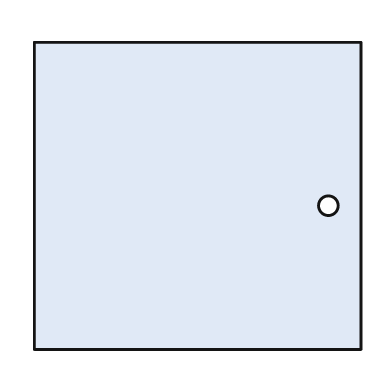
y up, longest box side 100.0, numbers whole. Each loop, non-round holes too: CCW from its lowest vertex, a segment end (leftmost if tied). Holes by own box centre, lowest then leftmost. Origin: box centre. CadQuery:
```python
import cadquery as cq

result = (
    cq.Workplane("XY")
    .moveTo(-50.0, -47.0)
    .lineTo(50.0, -47.0)
    .lineTo(50.0, 47.0)
    .lineTo(-50.0, 47.0)
    .close()
    .moveTo(40.0, -3.0)
    .circle(3.0)
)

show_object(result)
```